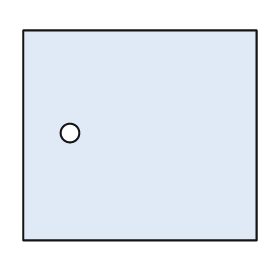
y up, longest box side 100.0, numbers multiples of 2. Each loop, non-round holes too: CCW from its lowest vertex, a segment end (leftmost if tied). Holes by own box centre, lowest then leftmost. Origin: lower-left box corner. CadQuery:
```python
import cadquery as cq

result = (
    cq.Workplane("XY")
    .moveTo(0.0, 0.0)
    .lineTo(100.0, 0.0)
    .lineTo(100.0, 90.0)
    .lineTo(0.0, 90.0)
    .close()
    .moveTo(20.0, 46.0)
    .circle(4.0)
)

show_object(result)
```